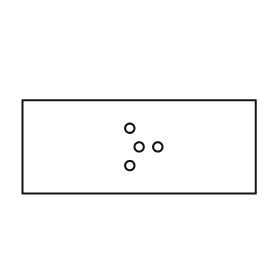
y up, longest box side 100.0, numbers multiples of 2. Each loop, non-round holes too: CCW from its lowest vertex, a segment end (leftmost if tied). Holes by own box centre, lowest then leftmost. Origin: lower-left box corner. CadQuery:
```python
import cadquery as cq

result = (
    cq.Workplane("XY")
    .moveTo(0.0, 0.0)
    .lineTo(100.0, 0.0)
    .lineTo(100.0, 40.0)
    .lineTo(0.0, 40.0)
    .close()
    .moveTo(46.0, 12.0)
    .circle(2.0)
    .moveTo(50.0, 20.0)
    .circle(2.0)
    .moveTo(58.0, 20.0)
    .circle(2.0)
    .moveTo(46.0, 28.0)
    .circle(2.0)
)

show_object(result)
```